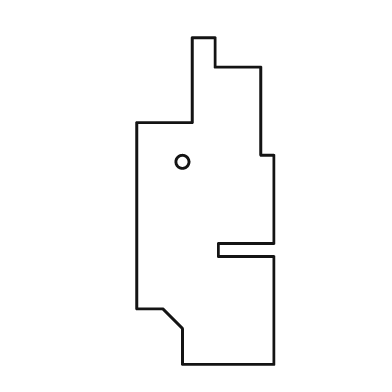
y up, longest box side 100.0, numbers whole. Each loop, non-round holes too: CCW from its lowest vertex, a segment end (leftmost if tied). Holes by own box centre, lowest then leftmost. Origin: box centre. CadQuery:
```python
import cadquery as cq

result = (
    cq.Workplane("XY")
    .moveTo(-7.0, -50.0)
    .lineTo(21.0, -50.0)
    .lineTo(21.0, -17.0)
    .lineTo(4.0, -17.0)
    .lineTo(4.0, -13.0)
    .lineTo(21.0, -13.0)
    .lineTo(21.0, 14.0)
    .lineTo(17.0, 14.0)
    .lineTo(17.0, 41.0)
    .lineTo(3.0, 41.0)
    .lineTo(3.0, 50.0)
    .lineTo(-4.0, 50.0)
    .lineTo(-4.0, 24.0)
    .lineTo(-21.0, 24.0)
    .lineTo(-21.0, -33.0)
    .lineTo(-13.0, -33.0)
    .lineTo(-7.0, -39.0)
    .close()
    .moveTo(-7.0, 12.0)
    .circle(2.0)
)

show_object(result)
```